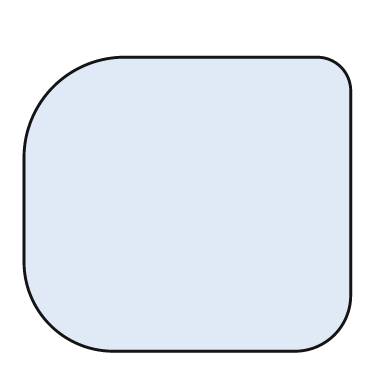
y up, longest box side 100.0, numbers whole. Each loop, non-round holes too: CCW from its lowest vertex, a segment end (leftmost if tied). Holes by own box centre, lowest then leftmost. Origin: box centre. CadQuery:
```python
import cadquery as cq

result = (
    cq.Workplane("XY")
    .moveTo(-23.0, -45.0)
    .lineTo(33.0, -45.0)
    .threePointArc((45.0, -40.0), (50.0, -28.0))
    .lineTo(50.0, 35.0)
    .threePointArc((47.0, 42.0), (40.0, 45.0))
    .lineTo(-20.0, 45.0)
    .threePointArc((-41.0, 36.0), (-50.0, 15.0))
    .lineTo(-50.0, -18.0)
    .threePointArc((-42.0, -37.0), (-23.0, -45.0))
    .close()
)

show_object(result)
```